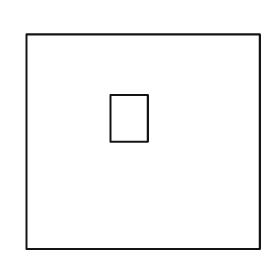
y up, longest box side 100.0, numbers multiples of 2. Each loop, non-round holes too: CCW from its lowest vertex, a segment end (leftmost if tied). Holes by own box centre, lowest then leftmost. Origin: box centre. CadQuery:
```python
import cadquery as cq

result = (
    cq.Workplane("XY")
    .moveTo(-50.0, -46.0)
    .lineTo(50.0, -46.0)
    .lineTo(50.0, 46.0)
    .lineTo(-50.0, 46.0)
    .close()
    .moveTo(-14.0, 0.0)
    .lineTo(2.0, 0.0)
    .lineTo(2.0, 20.0)
    .lineTo(-14.0, 20.0)
    .close()
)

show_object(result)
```